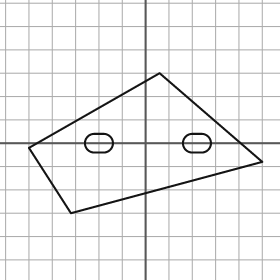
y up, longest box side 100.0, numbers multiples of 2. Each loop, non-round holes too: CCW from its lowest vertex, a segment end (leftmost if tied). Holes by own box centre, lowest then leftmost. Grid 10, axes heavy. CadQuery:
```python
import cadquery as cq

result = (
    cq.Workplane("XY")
    .moveTo(-32.0, -30.0)
    .lineTo(50.0, -8.0)
    .lineTo(6.0, 30.0)
    .lineTo(-50.0, -2.0)
    .close()
    .moveTo(-22.0, -4.0)
    .lineTo(-18.0, -4.0)
    .threePointArc((-14.0, 0.0), (-18.0, 4.0))
    .lineTo(-22.0, 4.0)
    .threePointArc((-26.0, 0.0), (-22.0, -4.0))
    .close()
    .moveTo(20.0, -4.0)
    .lineTo(24.0, -4.0)
    .threePointArc((28.0, 0.0), (24.0, 4.0))
    .lineTo(20.0, 4.0)
    .threePointArc((16.0, 0.0), (20.0, -4.0))
    .close()
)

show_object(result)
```